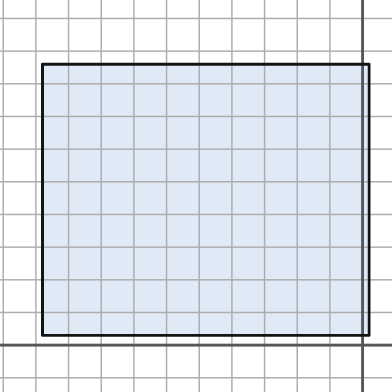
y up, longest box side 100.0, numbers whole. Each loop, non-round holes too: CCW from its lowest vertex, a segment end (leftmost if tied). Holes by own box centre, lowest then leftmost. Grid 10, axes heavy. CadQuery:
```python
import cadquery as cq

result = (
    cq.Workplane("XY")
    .moveTo(-98.0, 3.0)
    .lineTo(2.0, 3.0)
    .lineTo(2.0, 86.0)
    .lineTo(-98.0, 86.0)
    .close()
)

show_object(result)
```